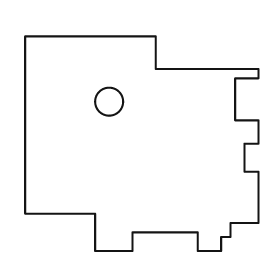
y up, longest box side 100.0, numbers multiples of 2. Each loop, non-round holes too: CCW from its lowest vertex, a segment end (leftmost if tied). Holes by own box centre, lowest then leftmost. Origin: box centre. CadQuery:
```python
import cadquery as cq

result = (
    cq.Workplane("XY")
    .moveTo(-20.0, -46.0)
    .lineTo(-4.0, -46.0)
    .lineTo(-4.0, -38.0)
    .lineTo(24.0, -38.0)
    .lineTo(24.0, -46.0)
    .lineTo(34.0, -46.0)
    .lineTo(34.0, -40.0)
    .lineTo(38.0, -40.0)
    .lineTo(38.0, -34.0)
    .lineTo(50.0, -34.0)
    .lineTo(50.0, -12.0)
    .lineTo(44.0, -12.0)
    .lineTo(44.0, 0.0)
    .lineTo(50.0, 0.0)
    .lineTo(50.0, 10.0)
    .lineTo(40.0, 10.0)
    .lineTo(40.0, 28.0)
    .lineTo(50.0, 28.0)
    .lineTo(50.0, 32.0)
    .lineTo(6.0, 32.0)
    .lineTo(6.0, 46.0)
    .lineTo(-50.0, 46.0)
    .lineTo(-50.0, -30.0)
    .lineTo(-20.0, -30.0)
    .close()
    .moveTo(-14.0, 18.0)
    .circle(6.0)
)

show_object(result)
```